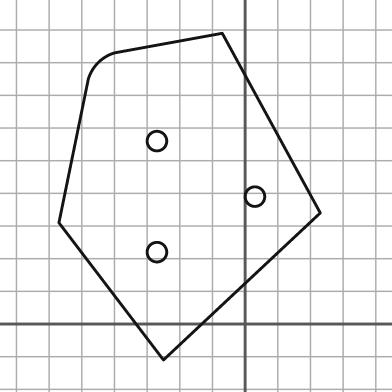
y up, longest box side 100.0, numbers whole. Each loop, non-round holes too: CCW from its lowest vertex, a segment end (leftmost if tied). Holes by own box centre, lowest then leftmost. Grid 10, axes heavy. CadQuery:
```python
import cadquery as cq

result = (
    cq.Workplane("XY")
    .moveTo(-25.0, -11.0)
    .lineTo(23.0, 34.0)
    .lineTo(-7.0, 89.0)
    .lineTo(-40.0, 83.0)
    .threePointArc((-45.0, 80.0), (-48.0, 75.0))
    .lineTo(-57.0, 31.0)
    .close()
    .moveTo(-27.0, 22.0)
    .circle(3.0)
    .moveTo(3.0, 39.0)
    .circle(3.0)
    .moveTo(-27.0, 56.0)
    .circle(3.0)
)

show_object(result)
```